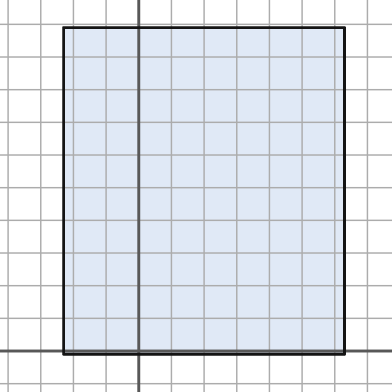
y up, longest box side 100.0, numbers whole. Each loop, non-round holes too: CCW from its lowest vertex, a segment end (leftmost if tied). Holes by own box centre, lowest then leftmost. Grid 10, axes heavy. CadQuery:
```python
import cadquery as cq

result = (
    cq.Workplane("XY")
    .moveTo(-23.0, -1.0)
    .lineTo(63.0, -1.0)
    .lineTo(63.0, 99.0)
    .lineTo(-23.0, 99.0)
    .close()
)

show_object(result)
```